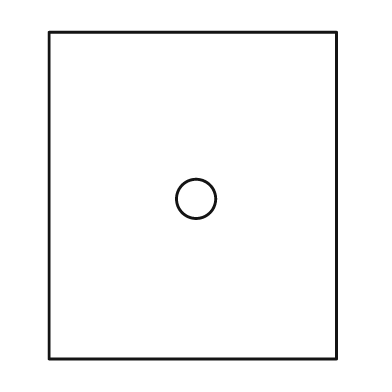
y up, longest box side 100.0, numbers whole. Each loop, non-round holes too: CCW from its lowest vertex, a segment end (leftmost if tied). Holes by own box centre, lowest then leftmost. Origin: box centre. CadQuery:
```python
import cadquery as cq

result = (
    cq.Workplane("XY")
    .moveTo(-44.0, -50.0)
    .lineTo(44.0, -50.0)
    .lineTo(44.0, 50.0)
    .lineTo(-44.0, 50.0)
    .close()
    .moveTo(1.0, -1.0)
    .circle(6.0)
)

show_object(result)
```